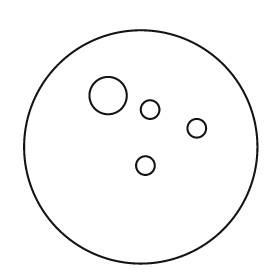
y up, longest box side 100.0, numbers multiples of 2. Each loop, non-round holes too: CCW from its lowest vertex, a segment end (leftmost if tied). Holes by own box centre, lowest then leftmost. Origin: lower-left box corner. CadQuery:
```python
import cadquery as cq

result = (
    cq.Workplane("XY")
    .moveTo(50.0, 50.0)
    .circle(50.0)
    .moveTo(52.0, 42.0)
    .circle(4.0)
    .moveTo(74.0, 58.0)
    .circle(4.0)
    .moveTo(54.0, 66.0)
    .circle(4.0)
    .moveTo(36.0, 72.0)
    .circle(8.0)
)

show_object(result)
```